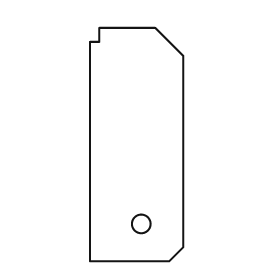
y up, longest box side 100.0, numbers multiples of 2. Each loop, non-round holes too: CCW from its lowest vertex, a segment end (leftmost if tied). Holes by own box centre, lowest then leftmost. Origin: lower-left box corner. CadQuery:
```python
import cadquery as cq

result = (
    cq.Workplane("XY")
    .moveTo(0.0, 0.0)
    .lineTo(34.0, 0.0)
    .lineTo(40.0, 6.0)
    .lineTo(40.0, 88.0)
    .lineTo(28.0, 100.0)
    .lineTo(4.0, 100.0)
    .lineTo(4.0, 94.0)
    .lineTo(0.0, 94.0)
    .close()
    .moveTo(22.0, 16.0)
    .circle(4.0)
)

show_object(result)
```